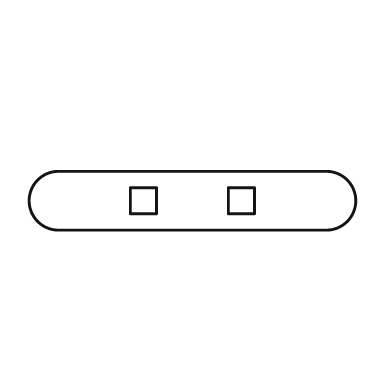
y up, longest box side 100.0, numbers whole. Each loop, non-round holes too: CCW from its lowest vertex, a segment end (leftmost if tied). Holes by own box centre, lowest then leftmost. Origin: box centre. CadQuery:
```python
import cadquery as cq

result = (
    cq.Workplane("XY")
    .moveTo(-41.0, -9.0)
    .lineTo(41.0, -9.0)
    .threePointArc((50.0, 0.0), (41.0, 9.0))
    .lineTo(-41.0, 9.0)
    .threePointArc((-50.0, 0.0), (-41.0, -9.0))
    .close()
    .moveTo(-19.0, -4.0)
    .lineTo(-11.0, -4.0)
    .lineTo(-11.0, 4.0)
    .lineTo(-19.0, 4.0)
    .close()
    .moveTo(11.0, -4.0)
    .lineTo(19.0, -4.0)
    .lineTo(19.0, 4.0)
    .lineTo(11.0, 4.0)
    .close()
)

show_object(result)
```